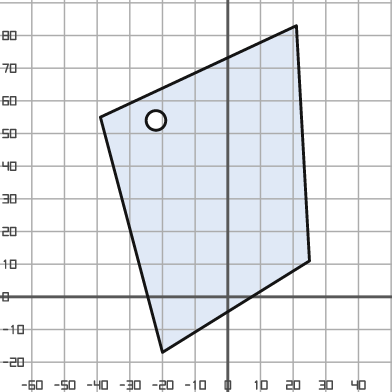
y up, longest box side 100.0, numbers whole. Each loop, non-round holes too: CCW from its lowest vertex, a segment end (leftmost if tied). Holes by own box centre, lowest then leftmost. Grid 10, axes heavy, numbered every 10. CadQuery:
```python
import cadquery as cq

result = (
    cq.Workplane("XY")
    .moveTo(-20.0, -17.0)
    .lineTo(25.0, 11.0)
    .lineTo(21.0, 83.0)
    .lineTo(-39.0, 55.0)
    .close()
    .moveTo(-22.0, 54.0)
    .circle(3.0)
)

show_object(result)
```